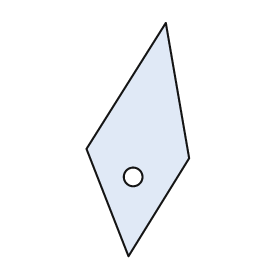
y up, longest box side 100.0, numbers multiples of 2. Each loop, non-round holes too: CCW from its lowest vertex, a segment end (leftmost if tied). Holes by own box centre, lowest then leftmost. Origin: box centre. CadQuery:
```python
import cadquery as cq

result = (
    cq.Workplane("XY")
    .moveTo(-4.0, -50.0)
    .lineTo(22.0, -8.0)
    .lineTo(12.0, 50.0)
    .lineTo(-22.0, -4.0)
    .close()
    .moveTo(-2.0, -16.0)
    .circle(4.0)
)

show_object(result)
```